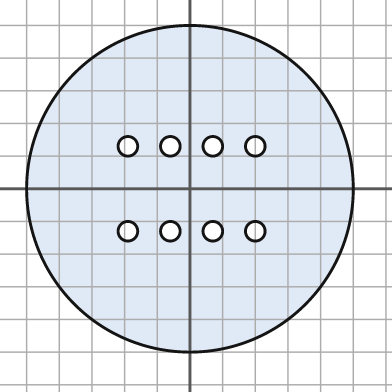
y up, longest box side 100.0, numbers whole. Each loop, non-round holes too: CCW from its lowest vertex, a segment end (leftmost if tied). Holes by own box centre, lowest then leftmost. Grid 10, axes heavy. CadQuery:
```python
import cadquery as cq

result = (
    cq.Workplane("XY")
    .moveTo(0.0, 0.0)
    .circle(50.0)
    .moveTo(-19.0, -13.0)
    .circle(3.0)
    .moveTo(-6.0, -13.0)
    .circle(3.0)
    .moveTo(7.0, -13.0)
    .circle(3.0)
    .moveTo(20.0, -13.0)
    .circle(3.0)
    .moveTo(-19.0, 13.0)
    .circle(3.0)
    .moveTo(-6.0, 13.0)
    .circle(3.0)
    .moveTo(7.0, 13.0)
    .circle(3.0)
    .moveTo(20.0, 13.0)
    .circle(3.0)
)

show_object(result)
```